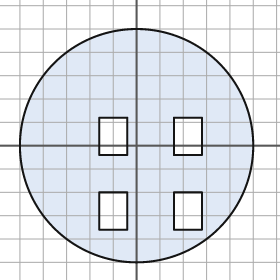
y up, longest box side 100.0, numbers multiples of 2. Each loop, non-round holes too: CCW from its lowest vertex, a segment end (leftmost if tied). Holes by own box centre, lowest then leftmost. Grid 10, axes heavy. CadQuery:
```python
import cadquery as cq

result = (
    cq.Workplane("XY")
    .moveTo(0.0, 0.0)
    .circle(50.0)
    .moveTo(-16.0, -36.0)
    .lineTo(-4.0, -36.0)
    .lineTo(-4.0, -20.0)
    .lineTo(-16.0, -20.0)
    .close()
    .moveTo(16.0, -36.0)
    .lineTo(28.0, -36.0)
    .lineTo(28.0, -20.0)
    .lineTo(16.0, -20.0)
    .close()
    .moveTo(-16.0, -4.0)
    .lineTo(-4.0, -4.0)
    .lineTo(-4.0, 12.0)
    .lineTo(-16.0, 12.0)
    .close()
    .moveTo(16.0, -4.0)
    .lineTo(28.0, -4.0)
    .lineTo(28.0, 12.0)
    .lineTo(16.0, 12.0)
    .close()
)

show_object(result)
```